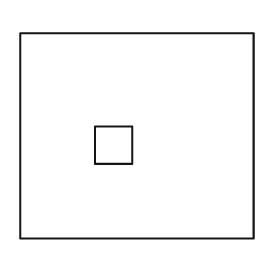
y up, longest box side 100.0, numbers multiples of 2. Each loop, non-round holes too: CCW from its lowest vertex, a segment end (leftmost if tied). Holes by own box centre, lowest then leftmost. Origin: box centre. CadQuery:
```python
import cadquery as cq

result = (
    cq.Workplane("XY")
    .moveTo(-50.0, -44.0)
    .lineTo(50.0, -44.0)
    .lineTo(50.0, 44.0)
    .lineTo(-50.0, 44.0)
    .close()
    .moveTo(-18.0, -12.0)
    .lineTo(-2.0, -12.0)
    .lineTo(-2.0, 4.0)
    .lineTo(-18.0, 4.0)
    .close()
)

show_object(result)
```